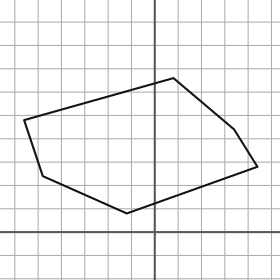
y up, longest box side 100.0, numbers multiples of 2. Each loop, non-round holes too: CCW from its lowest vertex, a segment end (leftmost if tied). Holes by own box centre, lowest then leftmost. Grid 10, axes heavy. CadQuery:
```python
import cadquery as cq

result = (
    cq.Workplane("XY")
    .moveTo(-12.0, 8.0)
    .lineTo(44.0, 28.0)
    .lineTo(34.0, 44.0)
    .lineTo(8.0, 66.0)
    .lineTo(-56.0, 48.0)
    .lineTo(-48.0, 24.0)
    .close()
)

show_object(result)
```